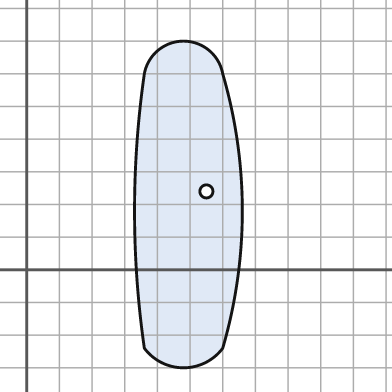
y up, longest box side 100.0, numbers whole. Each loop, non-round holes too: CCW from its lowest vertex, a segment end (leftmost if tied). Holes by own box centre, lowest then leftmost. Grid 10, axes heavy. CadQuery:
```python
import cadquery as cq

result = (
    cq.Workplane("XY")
    .moveTo(36.0, -24.0)
    .threePointArc((48.0, -30.0), (60.0, -24.0))
    .threePointArc((66.0, 18.0), (60.0, 60.0))
    .threePointArc((48.0, 70.0), (36.0, 60.0))
    .threePointArc((33.0, 18.0), (36.0, -24.0))
    .close()
    .moveTo(55.0, 24.0)
    .circle(2.0)
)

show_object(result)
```